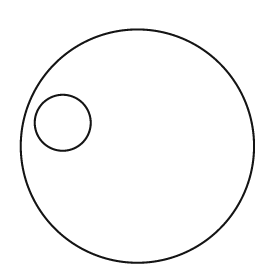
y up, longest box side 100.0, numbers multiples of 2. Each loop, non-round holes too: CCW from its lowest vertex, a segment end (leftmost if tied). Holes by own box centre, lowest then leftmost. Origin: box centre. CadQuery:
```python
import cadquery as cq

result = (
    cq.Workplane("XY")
    .moveTo(0.0, 0.0)
    .circle(50.0)
    .moveTo(-32.0, 10.0)
    .circle(12.0)
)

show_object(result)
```